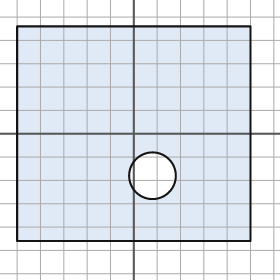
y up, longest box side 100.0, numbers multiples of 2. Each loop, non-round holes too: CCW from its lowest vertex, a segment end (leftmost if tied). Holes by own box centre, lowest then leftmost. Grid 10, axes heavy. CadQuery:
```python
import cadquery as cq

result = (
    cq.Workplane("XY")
    .moveTo(-50.0, -46.0)
    .lineTo(50.0, -46.0)
    .lineTo(50.0, 46.0)
    .lineTo(-50.0, 46.0)
    .close()
    .moveTo(8.0, -18.0)
    .circle(10.0)
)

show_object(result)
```